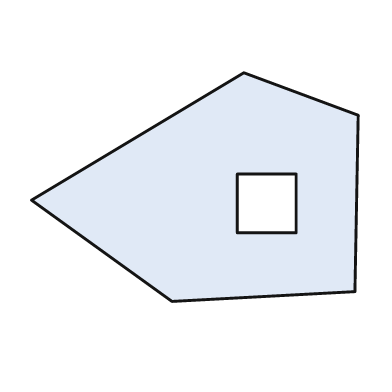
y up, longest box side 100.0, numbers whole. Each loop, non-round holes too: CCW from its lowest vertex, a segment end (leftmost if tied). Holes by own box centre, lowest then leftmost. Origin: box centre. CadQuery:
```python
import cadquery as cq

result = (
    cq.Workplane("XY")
    .moveTo(-7.0, -35.0)
    .lineTo(49.0, -32.0)
    .lineTo(50.0, 22.0)
    .lineTo(15.0, 35.0)
    .lineTo(-50.0, -4.0)
    .close()
    .moveTo(13.0, -14.0)
    .lineTo(31.0, -14.0)
    .lineTo(31.0, 4.0)
    .lineTo(13.0, 4.0)
    .close()
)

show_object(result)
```